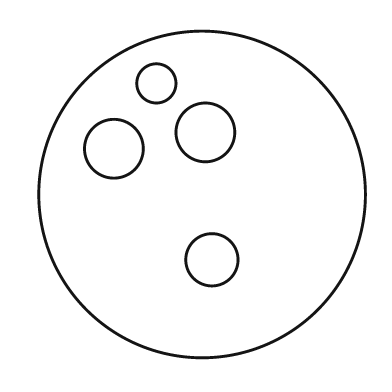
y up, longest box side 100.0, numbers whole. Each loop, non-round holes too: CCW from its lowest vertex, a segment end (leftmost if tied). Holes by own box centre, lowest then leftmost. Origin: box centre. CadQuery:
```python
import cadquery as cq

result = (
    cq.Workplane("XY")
    .moveTo(0.0, 0.0)
    .circle(50.0)
    .moveTo(3.0, -20.0)
    .circle(8.0)
    .moveTo(-27.0, 14.0)
    .circle(9.0)
    .moveTo(1.0, 19.0)
    .circle(9.0)
    .moveTo(-14.0, 34.0)
    .circle(6.0)
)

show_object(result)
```